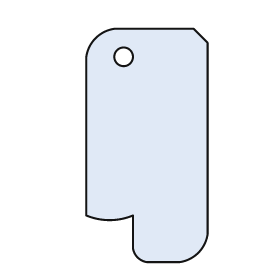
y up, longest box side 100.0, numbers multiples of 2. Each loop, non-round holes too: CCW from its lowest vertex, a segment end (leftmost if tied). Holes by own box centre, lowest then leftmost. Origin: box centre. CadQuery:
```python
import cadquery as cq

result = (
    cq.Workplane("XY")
    .moveTo(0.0, -50.0)
    .lineTo(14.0, -50.0)
    .threePointArc((22.0, -46.0), (26.0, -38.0))
    .lineTo(26.0, 44.0)
    .lineTo(20.0, 50.0)
    .lineTo(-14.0, 50.0)
    .threePointArc((-22.0, 46.0), (-26.0, 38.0))
    .lineTo(-26.0, -30.0)
    .threePointArc((-16.0, -32.0), (-6.0, -30.0))
    .lineTo(-6.0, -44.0)
    .threePointArc((-4.0, -48.0), (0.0, -50.0))
    .close()
    .moveTo(-10.0, 38.0)
    .circle(4.0)
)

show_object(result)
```